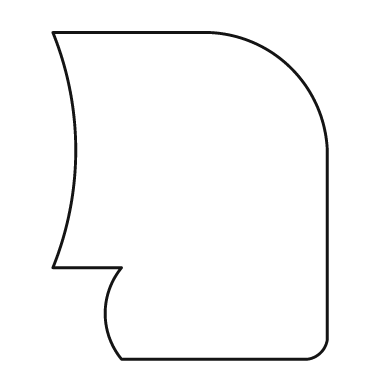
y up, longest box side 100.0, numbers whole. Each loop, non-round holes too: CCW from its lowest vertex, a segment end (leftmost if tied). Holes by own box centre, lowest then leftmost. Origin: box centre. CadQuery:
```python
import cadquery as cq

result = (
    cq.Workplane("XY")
    .moveTo(-21.0, -50.0)
    .lineTo(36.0, -50.0)
    .threePointArc((40.0, -48.0), (42.0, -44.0))
    .lineTo(42.0, 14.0)
    .threePointArc((31.0, 39.0), (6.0, 50.0))
    .lineTo(-42.0, 50.0)
    .threePointArc((-35.0, 14.0), (-42.0, -22.0))
    .lineTo(-21.0, -22.0)
    .threePointArc((-26.0, -36.0), (-21.0, -50.0))
    .close()
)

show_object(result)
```